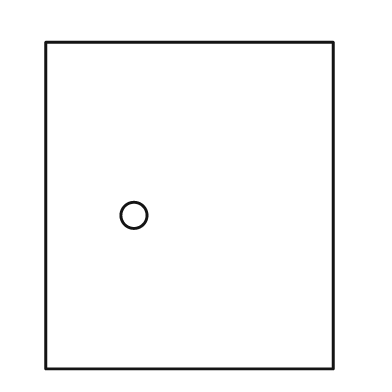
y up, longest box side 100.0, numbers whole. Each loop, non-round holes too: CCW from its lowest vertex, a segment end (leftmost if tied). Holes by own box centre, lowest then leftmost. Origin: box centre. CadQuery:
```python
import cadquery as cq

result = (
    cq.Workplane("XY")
    .moveTo(-44.0, -50.0)
    .lineTo(44.0, -50.0)
    .lineTo(44.0, 50.0)
    .lineTo(-44.0, 50.0)
    .close()
    .moveTo(-17.0, -3.0)
    .circle(4.0)
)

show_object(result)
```